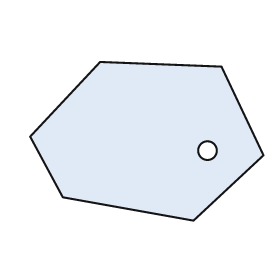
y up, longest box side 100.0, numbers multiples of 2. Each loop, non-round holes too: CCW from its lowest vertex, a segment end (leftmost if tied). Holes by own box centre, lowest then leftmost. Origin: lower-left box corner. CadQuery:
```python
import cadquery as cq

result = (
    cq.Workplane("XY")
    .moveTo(70.0, 0.0)
    .lineTo(100.0, 28.0)
    .lineTo(82.0, 66.0)
    .lineTo(30.0, 68.0)
    .lineTo(0.0, 36.0)
    .lineTo(14.0, 10.0)
    .close()
    .moveTo(76.0, 30.0)
    .circle(4.0)
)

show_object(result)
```